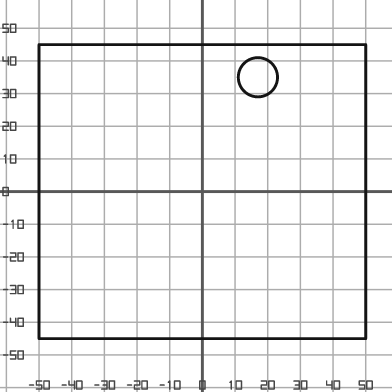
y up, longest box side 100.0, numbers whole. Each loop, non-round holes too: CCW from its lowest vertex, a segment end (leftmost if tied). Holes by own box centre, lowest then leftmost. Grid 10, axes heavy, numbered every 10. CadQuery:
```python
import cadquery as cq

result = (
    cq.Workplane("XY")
    .moveTo(-50.0, -45.0)
    .lineTo(50.0, -45.0)
    .lineTo(50.0, 45.0)
    .lineTo(-50.0, 45.0)
    .close()
    .moveTo(17.0, 35.0)
    .circle(6.0)
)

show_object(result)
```